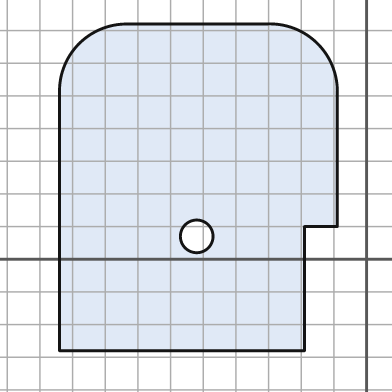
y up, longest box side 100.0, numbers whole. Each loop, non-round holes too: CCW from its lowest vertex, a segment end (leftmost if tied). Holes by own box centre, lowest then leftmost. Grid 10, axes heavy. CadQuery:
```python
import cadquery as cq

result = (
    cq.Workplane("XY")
    .moveTo(-94.0, -28.0)
    .lineTo(-19.0, -28.0)
    .lineTo(-19.0, 10.0)
    .lineTo(-9.0, 10.0)
    .lineTo(-9.0, 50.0)
    .threePointArc((-15.0, 66.0), (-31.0, 72.0))
    .lineTo(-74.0, 72.0)
    .threePointArc((-88.0, 66.0), (-94.0, 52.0))
    .close()
    .moveTo(-52.0, 7.0)
    .circle(5.0)
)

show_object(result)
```